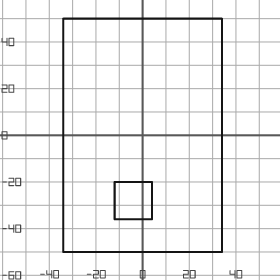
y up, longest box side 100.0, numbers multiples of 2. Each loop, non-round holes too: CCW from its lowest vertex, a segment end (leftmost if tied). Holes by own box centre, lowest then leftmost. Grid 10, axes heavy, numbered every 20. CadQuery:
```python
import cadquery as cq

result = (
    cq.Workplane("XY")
    .moveTo(-34.0, -50.0)
    .lineTo(34.0, -50.0)
    .lineTo(34.0, 50.0)
    .lineTo(-34.0, 50.0)
    .close()
    .moveTo(-12.0, -36.0)
    .lineTo(4.0, -36.0)
    .lineTo(4.0, -20.0)
    .lineTo(-12.0, -20.0)
    .close()
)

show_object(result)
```